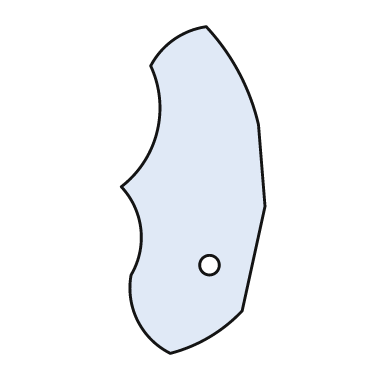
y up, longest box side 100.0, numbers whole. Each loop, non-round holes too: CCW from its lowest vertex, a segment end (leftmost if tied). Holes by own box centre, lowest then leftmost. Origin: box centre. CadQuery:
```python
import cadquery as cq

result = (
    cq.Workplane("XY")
    .moveTo(-7.0, -50.0)
    .threePointArc((5.0, -45.0), (15.0, -37.0))
    .lineTo(22.0, -5.0)
    .lineTo(20.0, 20.0)
    .threePointArc((14.0, 36.0), (4.0, 50.0))
    .threePointArc((-6.0, 46.0), (-13.0, 38.0))
    .threePointArc((-11.0, 18.0), (-22.0, 1.0))
    .threePointArc((-16.0, -12.0), (-19.0, -26.0))
    .threePointArc((-17.0, -40.0), (-7.0, -50.0))
    .close()
    .moveTo(5.0, -23.0)
    .circle(3.0)
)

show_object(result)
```